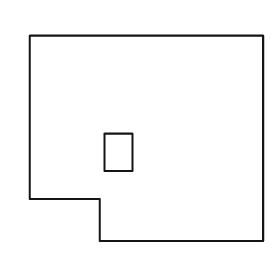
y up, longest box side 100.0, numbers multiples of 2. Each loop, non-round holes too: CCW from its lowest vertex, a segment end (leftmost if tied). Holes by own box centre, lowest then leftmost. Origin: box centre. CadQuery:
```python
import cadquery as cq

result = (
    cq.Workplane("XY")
    .moveTo(-20.0, -44.0)
    .lineTo(50.0, -44.0)
    .lineTo(50.0, 44.0)
    .lineTo(-50.0, 44.0)
    .lineTo(-50.0, -26.0)
    .lineTo(-20.0, -26.0)
    .close()
    .moveTo(-18.0, -14.0)
    .lineTo(-6.0, -14.0)
    .lineTo(-6.0, 2.0)
    .lineTo(-18.0, 2.0)
    .close()
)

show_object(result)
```